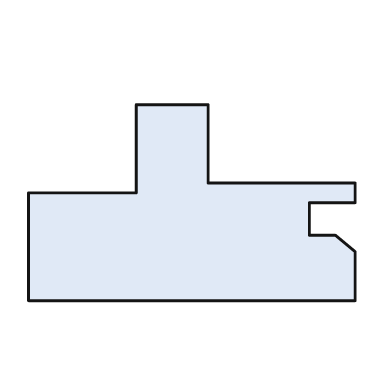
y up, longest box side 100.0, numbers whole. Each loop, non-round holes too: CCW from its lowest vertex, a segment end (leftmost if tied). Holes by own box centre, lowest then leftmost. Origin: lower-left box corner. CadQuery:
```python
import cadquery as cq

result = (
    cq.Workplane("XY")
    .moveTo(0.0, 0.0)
    .lineTo(100.0, 0.0)
    .lineTo(100.0, 15.0)
    .lineTo(94.0, 20.0)
    .lineTo(86.0, 20.0)
    .lineTo(86.0, 30.0)
    .lineTo(100.0, 30.0)
    .lineTo(100.0, 36.0)
    .lineTo(55.0, 36.0)
    .lineTo(55.0, 60.0)
    .lineTo(33.0, 60.0)
    .lineTo(33.0, 33.0)
    .lineTo(0.0, 33.0)
    .close()
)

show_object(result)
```